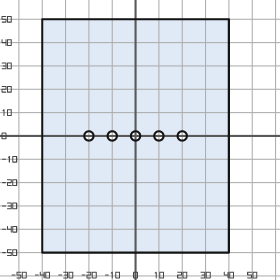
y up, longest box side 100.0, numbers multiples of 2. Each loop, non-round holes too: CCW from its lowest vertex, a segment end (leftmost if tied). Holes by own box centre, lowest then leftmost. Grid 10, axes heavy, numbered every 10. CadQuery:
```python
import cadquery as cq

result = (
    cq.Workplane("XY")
    .moveTo(-40.0, -50.0)
    .lineTo(40.0, -50.0)
    .lineTo(40.0, 50.0)
    .lineTo(-40.0, 50.0)
    .close()
    .moveTo(-20.0, 0.0)
    .circle(2.0)
    .moveTo(-10.0, 0.0)
    .circle(2.0)
    .moveTo(0.0, 0.0)
    .circle(2.0)
    .moveTo(10.0, 0.0)
    .circle(2.0)
    .moveTo(20.0, 0.0)
    .circle(2.0)
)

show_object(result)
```